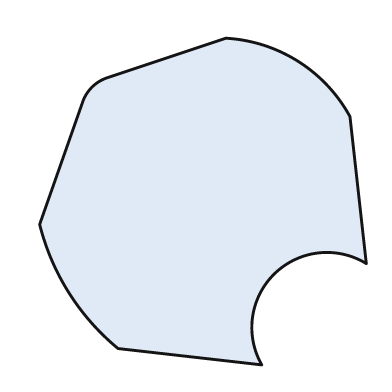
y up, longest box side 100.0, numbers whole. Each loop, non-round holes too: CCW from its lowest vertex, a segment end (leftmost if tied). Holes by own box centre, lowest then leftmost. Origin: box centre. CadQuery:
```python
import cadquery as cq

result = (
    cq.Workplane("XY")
    .moveTo(18.0, -50.0)
    .threePointArc((22.0, -22.0), (50.0, -19.0))
    .lineTo(45.0, 26.0)
    .threePointArc((29.0, 43.0), (7.0, 50.0))
    .lineTo(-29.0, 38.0)
    .threePointArc((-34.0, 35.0), (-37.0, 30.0))
    .lineTo(-50.0, -7.0)
    .threePointArc((-41.0, -28.0), (-26.0, -45.0))
    .close()
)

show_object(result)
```